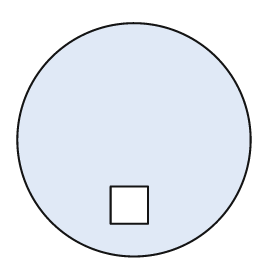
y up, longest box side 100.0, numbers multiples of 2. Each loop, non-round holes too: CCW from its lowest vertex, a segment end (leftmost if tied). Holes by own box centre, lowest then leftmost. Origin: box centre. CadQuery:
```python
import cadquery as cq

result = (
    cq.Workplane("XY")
    .moveTo(0.0, 0.0)
    .circle(50.0)
    .moveTo(-10.0, -36.0)
    .lineTo(6.0, -36.0)
    .lineTo(6.0, -20.0)
    .lineTo(-10.0, -20.0)
    .close()
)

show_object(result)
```